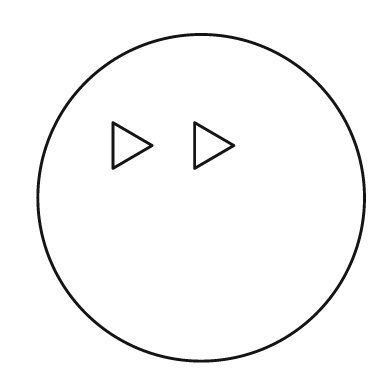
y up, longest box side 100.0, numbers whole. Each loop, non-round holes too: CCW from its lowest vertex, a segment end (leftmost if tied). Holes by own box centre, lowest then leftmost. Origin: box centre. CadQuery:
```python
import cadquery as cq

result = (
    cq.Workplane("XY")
    .moveTo(0.0, 0.0)
    .circle(50.0)
    .moveTo(-27.0, 9.0)
    .lineTo(-15.0, 16.0)
    .lineTo(-27.0, 23.0)
    .close()
    .moveTo(-2.0, 9.0)
    .lineTo(10.0, 16.0)
    .lineTo(-2.0, 23.0)
    .close()
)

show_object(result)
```